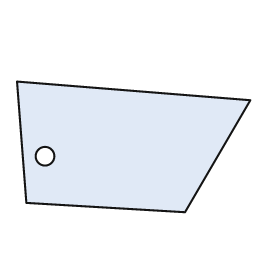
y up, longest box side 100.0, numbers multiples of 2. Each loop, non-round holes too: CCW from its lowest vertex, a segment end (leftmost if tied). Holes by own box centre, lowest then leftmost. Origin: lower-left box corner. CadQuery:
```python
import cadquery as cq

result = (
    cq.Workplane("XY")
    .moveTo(72.0, 0.0)
    .lineTo(100.0, 48.0)
    .lineTo(0.0, 56.0)
    .lineTo(4.0, 4.0)
    .close()
    .moveTo(12.0, 24.0)
    .circle(4.0)
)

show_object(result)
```